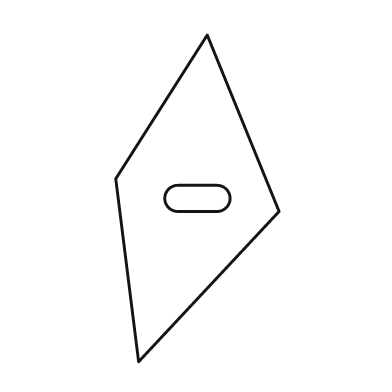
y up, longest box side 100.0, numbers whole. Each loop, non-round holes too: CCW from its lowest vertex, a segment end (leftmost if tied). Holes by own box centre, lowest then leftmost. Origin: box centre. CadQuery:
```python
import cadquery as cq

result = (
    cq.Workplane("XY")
    .moveTo(-18.0, -50.0)
    .lineTo(25.0, -4.0)
    .lineTo(3.0, 50.0)
    .lineTo(-25.0, 6.0)
    .close()
    .moveTo(-6.0, -4.0)
    .lineTo(6.0, -4.0)
    .threePointArc((10.0, 0.0), (6.0, 4.0))
    .lineTo(-6.0, 4.0)
    .threePointArc((-10.0, 0.0), (-6.0, -4.0))
    .close()
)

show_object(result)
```